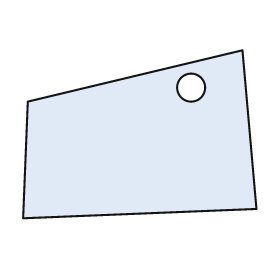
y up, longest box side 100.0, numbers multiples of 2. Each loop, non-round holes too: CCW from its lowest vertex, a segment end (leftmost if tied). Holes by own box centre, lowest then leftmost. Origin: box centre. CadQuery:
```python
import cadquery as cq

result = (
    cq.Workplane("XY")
    .moveTo(-50.0, -36.0)
    .lineTo(50.0, -32.0)
    .lineTo(44.0, 36.0)
    .lineTo(-48.0, 14.0)
    .close()
    .moveTo(22.0, 20.0)
    .circle(6.0)
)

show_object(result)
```